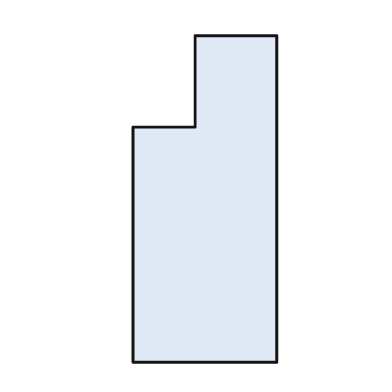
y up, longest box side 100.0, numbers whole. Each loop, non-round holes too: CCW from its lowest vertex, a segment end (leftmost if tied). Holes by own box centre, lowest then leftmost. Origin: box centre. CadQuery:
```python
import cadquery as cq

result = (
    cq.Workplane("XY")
    .moveTo(-22.0, -50.0)
    .lineTo(22.0, -50.0)
    .lineTo(22.0, 50.0)
    .lineTo(-3.0, 50.0)
    .lineTo(-3.0, 22.0)
    .lineTo(-22.0, 22.0)
    .close()
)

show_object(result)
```